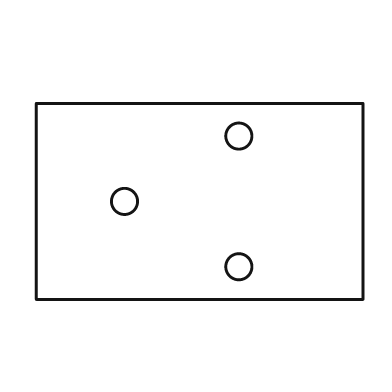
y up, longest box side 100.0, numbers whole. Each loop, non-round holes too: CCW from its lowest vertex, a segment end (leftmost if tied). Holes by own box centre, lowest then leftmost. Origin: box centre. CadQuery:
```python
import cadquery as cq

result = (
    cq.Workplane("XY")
    .moveTo(-50.0, -30.0)
    .lineTo(50.0, -30.0)
    .lineTo(50.0, 30.0)
    .lineTo(-50.0, 30.0)
    .close()
    .moveTo(12.0, -20.0)
    .circle(4.0)
    .moveTo(-23.0, 0.0)
    .circle(4.0)
    .moveTo(12.0, 20.0)
    .circle(4.0)
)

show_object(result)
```